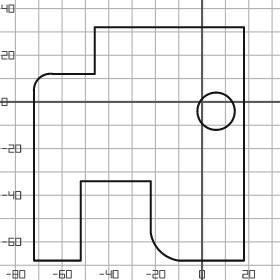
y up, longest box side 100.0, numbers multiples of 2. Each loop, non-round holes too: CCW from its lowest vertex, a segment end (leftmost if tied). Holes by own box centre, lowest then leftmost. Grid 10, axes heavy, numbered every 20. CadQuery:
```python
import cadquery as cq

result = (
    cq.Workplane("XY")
    .moveTo(-72.0, -68.0)
    .lineTo(-52.0, -68.0)
    .lineTo(-52.0, -34.0)
    .lineTo(-22.0, -34.0)
    .lineTo(-22.0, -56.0)
    .threePointArc((-18.0, -64.0), (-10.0, -68.0))
    .lineTo(18.0, -68.0)
    .lineTo(18.0, 32.0)
    .lineTo(-46.0, 32.0)
    .lineTo(-46.0, 12.0)
    .lineTo(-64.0, 12.0)
    .threePointArc((-70.0, 10.0), (-72.0, 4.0))
    .close()
    .moveTo(6.0, -4.0)
    .circle(8.0)
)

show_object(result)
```